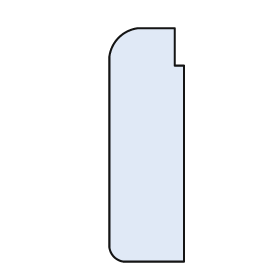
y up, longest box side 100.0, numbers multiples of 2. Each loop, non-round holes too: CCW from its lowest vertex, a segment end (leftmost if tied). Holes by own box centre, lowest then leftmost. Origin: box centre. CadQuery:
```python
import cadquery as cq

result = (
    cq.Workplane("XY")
    .moveTo(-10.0, -50.0)
    .lineTo(16.0, -50.0)
    .lineTo(16.0, 34.0)
    .lineTo(12.0, 34.0)
    .lineTo(12.0, 50.0)
    .lineTo(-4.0, 50.0)
    .threePointArc((-12.0, 46.0), (-16.0, 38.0))
    .lineTo(-16.0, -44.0)
    .threePointArc((-14.0, -48.0), (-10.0, -50.0))
    .close()
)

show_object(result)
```